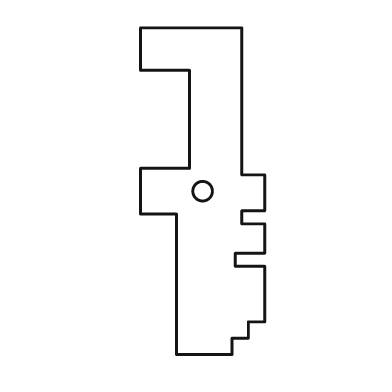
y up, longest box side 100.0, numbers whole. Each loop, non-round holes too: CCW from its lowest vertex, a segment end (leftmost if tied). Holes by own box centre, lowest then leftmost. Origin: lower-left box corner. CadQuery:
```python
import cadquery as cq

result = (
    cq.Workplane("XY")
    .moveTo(11.0, 0.0)
    .lineTo(28.0, 0.0)
    .lineTo(28.0, 5.0)
    .lineTo(33.0, 5.0)
    .lineTo(33.0, 10.0)
    .lineTo(38.0, 10.0)
    .lineTo(38.0, 27.0)
    .lineTo(29.0, 27.0)
    .lineTo(29.0, 31.0)
    .lineTo(38.0, 31.0)
    .lineTo(38.0, 40.0)
    .lineTo(31.0, 40.0)
    .lineTo(31.0, 44.0)
    .lineTo(38.0, 44.0)
    .lineTo(38.0, 55.0)
    .lineTo(31.0, 55.0)
    .lineTo(31.0, 100.0)
    .lineTo(0.0, 100.0)
    .lineTo(0.0, 87.0)
    .lineTo(15.0, 87.0)
    .lineTo(15.0, 57.0)
    .lineTo(0.0, 57.0)
    .lineTo(0.0, 43.0)
    .lineTo(11.0, 43.0)
    .close()
    .moveTo(19.0, 50.0)
    .circle(3.0)
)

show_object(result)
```